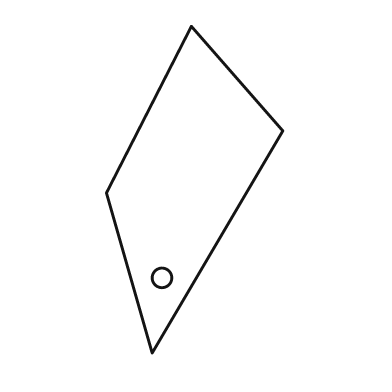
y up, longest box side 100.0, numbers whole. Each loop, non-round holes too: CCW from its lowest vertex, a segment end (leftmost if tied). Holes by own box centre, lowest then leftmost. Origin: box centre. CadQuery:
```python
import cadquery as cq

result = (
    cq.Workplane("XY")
    .moveTo(-13.0, -50.0)
    .lineTo(27.0, 18.0)
    .lineTo(-1.0, 50.0)
    .lineTo(-27.0, -1.0)
    .close()
    .moveTo(-10.0, -27.0)
    .circle(3.0)
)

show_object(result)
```